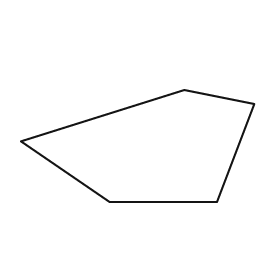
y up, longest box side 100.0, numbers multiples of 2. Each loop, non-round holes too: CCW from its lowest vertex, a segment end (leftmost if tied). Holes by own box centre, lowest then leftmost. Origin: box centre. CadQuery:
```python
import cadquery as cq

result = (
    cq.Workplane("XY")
    .moveTo(-12.0, -24.0)
    .lineTo(34.0, -24.0)
    .lineTo(50.0, 18.0)
    .lineTo(20.0, 24.0)
    .lineTo(-50.0, 2.0)
    .close()
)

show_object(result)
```